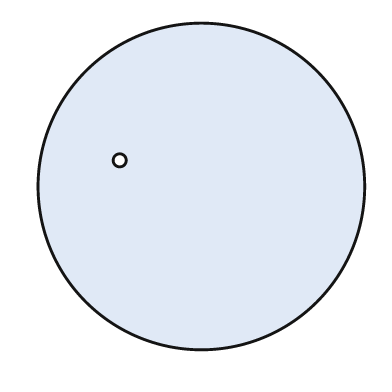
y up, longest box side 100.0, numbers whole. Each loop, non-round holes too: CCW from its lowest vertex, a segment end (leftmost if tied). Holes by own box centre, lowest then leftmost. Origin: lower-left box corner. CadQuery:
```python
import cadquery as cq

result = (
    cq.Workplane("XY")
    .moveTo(50.0, 50.0)
    .circle(50.0)
    .moveTo(25.0, 58.0)
    .circle(2.0)
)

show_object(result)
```